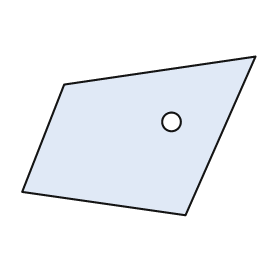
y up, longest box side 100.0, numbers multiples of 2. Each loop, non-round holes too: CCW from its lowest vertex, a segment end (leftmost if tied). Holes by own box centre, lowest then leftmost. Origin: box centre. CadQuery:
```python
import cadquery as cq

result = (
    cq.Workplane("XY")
    .moveTo(20.0, -34.0)
    .lineTo(50.0, 34.0)
    .lineTo(-32.0, 22.0)
    .lineTo(-50.0, -24.0)
    .close()
    .moveTo(14.0, 6.0)
    .circle(4.0)
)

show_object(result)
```